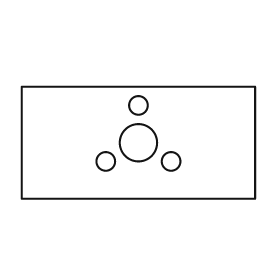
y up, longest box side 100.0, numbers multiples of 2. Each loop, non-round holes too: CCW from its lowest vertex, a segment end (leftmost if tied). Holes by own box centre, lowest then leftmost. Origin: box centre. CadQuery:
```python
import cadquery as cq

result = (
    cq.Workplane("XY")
    .moveTo(-50.0, -24.0)
    .lineTo(50.0, -24.0)
    .lineTo(50.0, 24.0)
    .lineTo(-50.0, 24.0)
    .close()
    .moveTo(-14.0, -8.0)
    .circle(4.0)
    .moveTo(14.0, -8.0)
    .circle(4.0)
    .moveTo(0.0, 0.0)
    .circle(8.0)
    .moveTo(0.0, 16.0)
    .circle(4.0)
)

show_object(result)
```